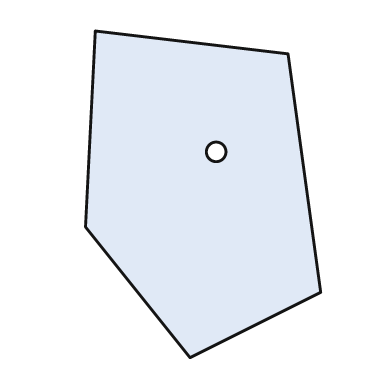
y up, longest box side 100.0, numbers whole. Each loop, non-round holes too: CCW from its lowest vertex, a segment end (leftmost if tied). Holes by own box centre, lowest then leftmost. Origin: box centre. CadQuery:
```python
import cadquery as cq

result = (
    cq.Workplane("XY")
    .moveTo(-4.0, -50.0)
    .lineTo(36.0, -30.0)
    .lineTo(26.0, 43.0)
    .lineTo(-33.0, 50.0)
    .lineTo(-36.0, -10.0)
    .close()
    .moveTo(4.0, 13.0)
    .circle(3.0)
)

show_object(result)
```